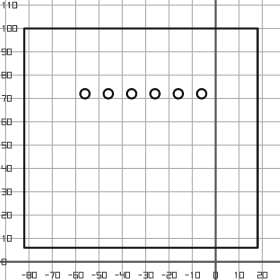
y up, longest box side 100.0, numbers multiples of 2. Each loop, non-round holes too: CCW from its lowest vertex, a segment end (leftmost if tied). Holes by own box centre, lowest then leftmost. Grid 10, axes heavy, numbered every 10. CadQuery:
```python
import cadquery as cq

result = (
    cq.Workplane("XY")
    .moveTo(-82.0, 6.0)
    .lineTo(18.0, 6.0)
    .lineTo(18.0, 100.0)
    .lineTo(-82.0, 100.0)
    .close()
    .moveTo(-56.0, 72.0)
    .circle(2.0)
    .moveTo(-46.0, 72.0)
    .circle(2.0)
    .moveTo(-36.0, 72.0)
    .circle(2.0)
    .moveTo(-26.0, 72.0)
    .circle(2.0)
    .moveTo(-16.0, 72.0)
    .circle(2.0)
    .moveTo(-6.0, 72.0)
    .circle(2.0)
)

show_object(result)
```